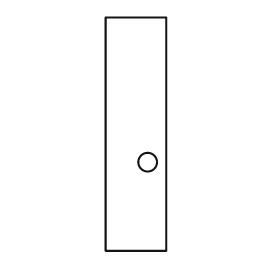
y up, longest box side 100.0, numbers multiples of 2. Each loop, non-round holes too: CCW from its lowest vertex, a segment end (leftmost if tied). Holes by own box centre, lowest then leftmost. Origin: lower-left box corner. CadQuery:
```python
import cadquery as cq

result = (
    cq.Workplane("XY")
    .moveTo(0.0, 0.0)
    .lineTo(26.0, 0.0)
    .lineTo(26.0, 100.0)
    .lineTo(0.0, 100.0)
    .close()
    .moveTo(18.0, 38.0)
    .circle(4.0)
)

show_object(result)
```